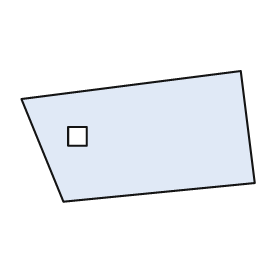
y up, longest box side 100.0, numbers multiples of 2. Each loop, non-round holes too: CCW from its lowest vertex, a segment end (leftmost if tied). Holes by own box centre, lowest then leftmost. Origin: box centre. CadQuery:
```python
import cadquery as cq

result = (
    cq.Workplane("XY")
    .moveTo(-32.0, -28.0)
    .lineTo(50.0, -20.0)
    .lineTo(44.0, 28.0)
    .lineTo(-50.0, 16.0)
    .close()
    .moveTo(-30.0, -4.0)
    .lineTo(-22.0, -4.0)
    .lineTo(-22.0, 4.0)
    .lineTo(-30.0, 4.0)
    .close()
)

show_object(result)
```